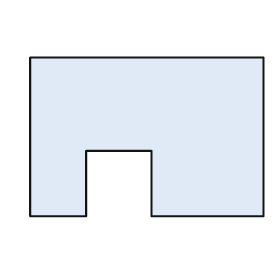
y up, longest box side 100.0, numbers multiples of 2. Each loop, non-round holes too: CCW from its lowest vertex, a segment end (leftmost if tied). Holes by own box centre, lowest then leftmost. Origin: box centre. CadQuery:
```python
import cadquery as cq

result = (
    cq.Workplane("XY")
    .moveTo(-50.0, -34.0)
    .lineTo(-26.0, -34.0)
    .lineTo(-26.0, -6.0)
    .lineTo(2.0, -6.0)
    .lineTo(2.0, -34.0)
    .lineTo(50.0, -34.0)
    .lineTo(50.0, 34.0)
    .lineTo(-50.0, 34.0)
    .close()
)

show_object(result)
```